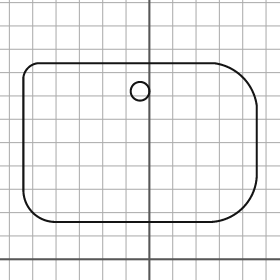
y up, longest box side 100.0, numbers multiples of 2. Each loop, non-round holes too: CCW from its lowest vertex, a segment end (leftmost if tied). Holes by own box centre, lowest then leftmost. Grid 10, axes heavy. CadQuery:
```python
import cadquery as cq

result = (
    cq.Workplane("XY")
    .moveTo(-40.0, 16.0)
    .lineTo(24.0, 16.0)
    .threePointArc((40.0, 22.0), (46.0, 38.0))
    .lineTo(46.0, 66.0)
    .threePointArc((40.0, 78.0), (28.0, 84.0))
    .lineTo(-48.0, 84.0)
    .threePointArc((-52.0, 82.0), (-54.0, 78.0))
    .lineTo(-54.0, 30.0)
    .threePointArc((-50.0, 20.0), (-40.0, 16.0))
    .close()
    .moveTo(-4.0, 72.0)
    .circle(4.0)
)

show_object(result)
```